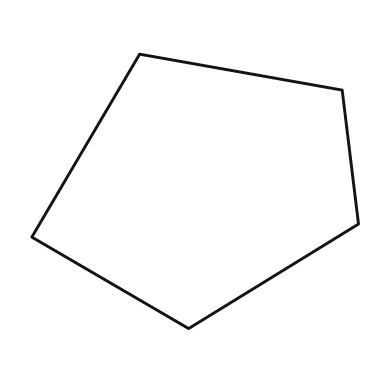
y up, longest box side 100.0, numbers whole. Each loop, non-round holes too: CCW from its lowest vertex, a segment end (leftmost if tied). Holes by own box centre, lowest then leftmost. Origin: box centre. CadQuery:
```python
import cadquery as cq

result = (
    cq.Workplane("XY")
    .moveTo(-2.0, -42.0)
    .lineTo(50.0, -10.0)
    .lineTo(45.0, 31.0)
    .lineTo(-17.0, 42.0)
    .lineTo(-50.0, -14.0)
    .close()
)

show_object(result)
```